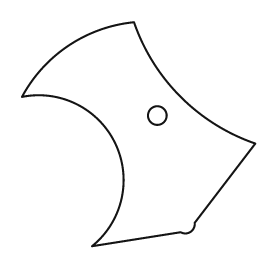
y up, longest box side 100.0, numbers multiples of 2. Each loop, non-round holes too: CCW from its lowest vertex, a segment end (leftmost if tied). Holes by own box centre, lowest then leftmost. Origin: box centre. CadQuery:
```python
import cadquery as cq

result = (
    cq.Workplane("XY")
    .moveTo(-20.0, -48.0)
    .lineTo(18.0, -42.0)
    .threePointArc((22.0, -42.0), (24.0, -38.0))
    .lineTo(50.0, -4.0)
    .threePointArc((18.0, 16.0), (-2.0, 48.0))
    .threePointArc((-30.0, 38.0), (-50.0, 16.0))
    .threePointArc((-10.0, -4.0), (-20.0, -48.0))
    .close()
    .moveTo(8.0, 8.0)
    .circle(4.0)
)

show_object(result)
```